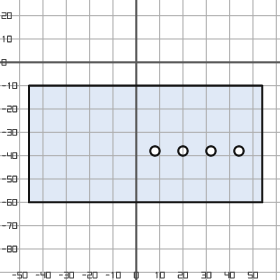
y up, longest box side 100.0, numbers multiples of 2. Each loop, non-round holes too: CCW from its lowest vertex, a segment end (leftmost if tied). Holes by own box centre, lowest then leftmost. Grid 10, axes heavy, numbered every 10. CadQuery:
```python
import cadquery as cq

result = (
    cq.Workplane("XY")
    .moveTo(-46.0, -60.0)
    .lineTo(54.0, -60.0)
    .lineTo(54.0, -10.0)
    .lineTo(-46.0, -10.0)
    .close()
    .moveTo(8.0, -38.0)
    .circle(2.0)
    .moveTo(20.0, -38.0)
    .circle(2.0)
    .moveTo(32.0, -38.0)
    .circle(2.0)
    .moveTo(44.0, -38.0)
    .circle(2.0)
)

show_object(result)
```